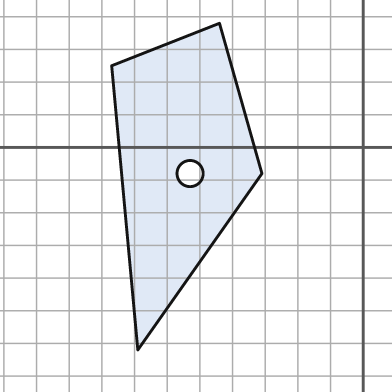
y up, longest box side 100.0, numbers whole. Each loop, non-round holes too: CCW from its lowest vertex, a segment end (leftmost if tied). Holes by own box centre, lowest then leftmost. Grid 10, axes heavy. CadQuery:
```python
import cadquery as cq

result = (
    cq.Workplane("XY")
    .moveTo(-69.0, -62.0)
    .lineTo(-31.0, -8.0)
    .lineTo(-44.0, 38.0)
    .lineTo(-77.0, 25.0)
    .close()
    .moveTo(-53.0, -8.0)
    .circle(4.0)
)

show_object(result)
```